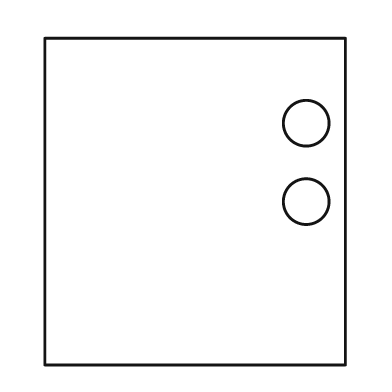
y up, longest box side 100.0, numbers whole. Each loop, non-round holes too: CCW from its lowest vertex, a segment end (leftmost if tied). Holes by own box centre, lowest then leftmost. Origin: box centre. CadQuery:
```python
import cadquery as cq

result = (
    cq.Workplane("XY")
    .moveTo(-46.0, -50.0)
    .lineTo(46.0, -50.0)
    .lineTo(46.0, 50.0)
    .lineTo(-46.0, 50.0)
    .close()
    .moveTo(34.0, 0.0)
    .circle(7.0)
    .moveTo(34.0, 24.0)
    .circle(7.0)
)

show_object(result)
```